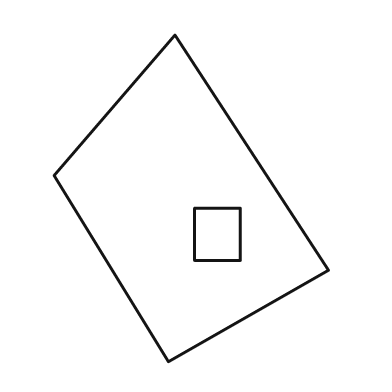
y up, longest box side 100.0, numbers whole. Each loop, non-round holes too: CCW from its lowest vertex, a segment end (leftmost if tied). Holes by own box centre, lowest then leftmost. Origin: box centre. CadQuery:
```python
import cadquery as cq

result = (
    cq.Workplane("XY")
    .moveTo(-7.0, -50.0)
    .lineTo(42.0, -22.0)
    .lineTo(-5.0, 50.0)
    .lineTo(-42.0, 7.0)
    .close()
    .moveTo(1.0, -19.0)
    .lineTo(15.0, -19.0)
    .lineTo(15.0, -3.0)
    .lineTo(1.0, -3.0)
    .close()
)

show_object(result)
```